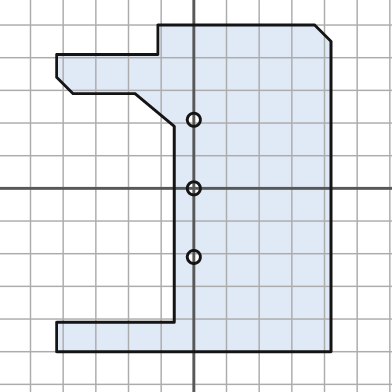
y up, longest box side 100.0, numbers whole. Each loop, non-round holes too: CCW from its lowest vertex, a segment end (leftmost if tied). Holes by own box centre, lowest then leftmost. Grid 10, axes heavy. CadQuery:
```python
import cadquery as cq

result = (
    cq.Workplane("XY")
    .moveTo(-42.0, -50.0)
    .lineTo(42.0, -50.0)
    .lineTo(42.0, 45.0)
    .lineTo(37.0, 50.0)
    .lineTo(-11.0, 50.0)
    .lineTo(-11.0, 41.0)
    .lineTo(-42.0, 41.0)
    .lineTo(-42.0, 34.0)
    .lineTo(-37.0, 29.0)
    .lineTo(-18.0, 29.0)
    .lineTo(-6.0, 19.0)
    .lineTo(-6.0, -41.0)
    .lineTo(-42.0, -41.0)
    .close()
    .moveTo(0.0, -21.0)
    .circle(2.0)
    .moveTo(0.0, 0.0)
    .circle(2.0)
    .moveTo(0.0, 21.0)
    .circle(2.0)
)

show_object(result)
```